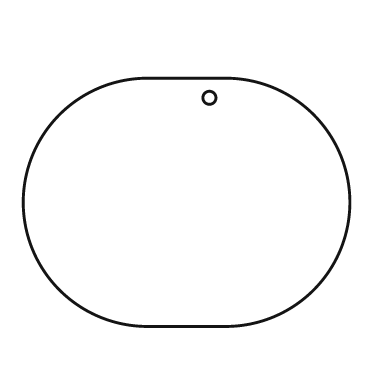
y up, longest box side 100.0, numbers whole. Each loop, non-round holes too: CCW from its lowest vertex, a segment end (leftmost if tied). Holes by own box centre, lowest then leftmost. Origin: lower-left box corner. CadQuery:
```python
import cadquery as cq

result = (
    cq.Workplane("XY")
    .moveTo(38.0, 0.0)
    .lineTo(62.0, 0.0)
    .threePointArc((100.0, 38.0), (62.0, 76.0))
    .lineTo(38.0, 76.0)
    .threePointArc((0.0, 38.0), (38.0, 0.0))
    .close()
    .moveTo(57.0, 70.0)
    .circle(2.0)
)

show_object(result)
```